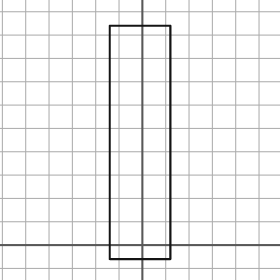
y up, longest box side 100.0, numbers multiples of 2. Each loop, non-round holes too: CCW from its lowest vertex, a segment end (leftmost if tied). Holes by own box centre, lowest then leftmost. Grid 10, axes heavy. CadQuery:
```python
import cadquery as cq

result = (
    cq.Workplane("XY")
    .moveTo(-14.0, -6.0)
    .lineTo(12.0, -6.0)
    .lineTo(12.0, 94.0)
    .lineTo(-14.0, 94.0)
    .close()
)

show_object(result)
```